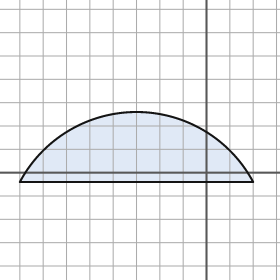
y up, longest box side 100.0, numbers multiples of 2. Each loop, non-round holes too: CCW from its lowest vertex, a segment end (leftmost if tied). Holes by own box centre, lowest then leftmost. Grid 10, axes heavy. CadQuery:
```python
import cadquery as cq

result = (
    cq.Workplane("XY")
    .moveTo(-80.0, -4.0)
    .lineTo(20.0, -4.0)
    .threePointArc((-30.0, 26.0), (-80.0, -4.0))
    .close()
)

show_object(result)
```